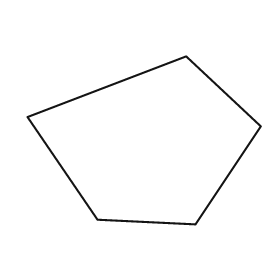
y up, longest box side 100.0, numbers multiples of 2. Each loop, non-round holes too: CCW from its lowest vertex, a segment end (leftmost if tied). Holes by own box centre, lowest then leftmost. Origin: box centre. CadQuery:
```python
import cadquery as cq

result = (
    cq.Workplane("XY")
    .moveTo(22.0, -36.0)
    .lineTo(50.0, 6.0)
    .lineTo(18.0, 36.0)
    .lineTo(-50.0, 10.0)
    .lineTo(-20.0, -34.0)
    .close()
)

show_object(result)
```